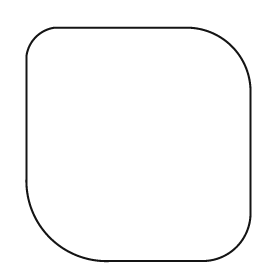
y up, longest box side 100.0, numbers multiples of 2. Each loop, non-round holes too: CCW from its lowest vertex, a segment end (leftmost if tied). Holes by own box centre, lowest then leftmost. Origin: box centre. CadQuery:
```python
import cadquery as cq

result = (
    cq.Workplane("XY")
    .moveTo(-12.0, -50.0)
    .lineTo(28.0, -50.0)
    .threePointArc((42.0, -44.0), (48.0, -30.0))
    .lineTo(48.0, 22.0)
    .threePointArc((40.0, 42.0), (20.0, 50.0))
    .lineTo(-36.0, 50.0)
    .threePointArc((-44.0, 46.0), (-48.0, 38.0))
    .lineTo(-48.0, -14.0)
    .threePointArc((-38.0, -40.0), (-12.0, -50.0))
    .close()
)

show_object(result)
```